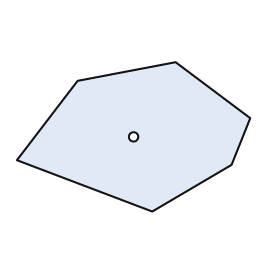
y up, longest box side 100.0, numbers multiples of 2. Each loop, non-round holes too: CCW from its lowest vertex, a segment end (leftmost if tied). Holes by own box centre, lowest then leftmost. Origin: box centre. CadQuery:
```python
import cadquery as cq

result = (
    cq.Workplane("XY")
    .moveTo(8.0, -32.0)
    .lineTo(42.0, -12.0)
    .lineTo(50.0, 8.0)
    .lineTo(18.0, 32.0)
    .lineTo(-24.0, 24.0)
    .lineTo(-50.0, -10.0)
    .close()
    .moveTo(0.0, 0.0)
    .circle(2.0)
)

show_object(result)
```